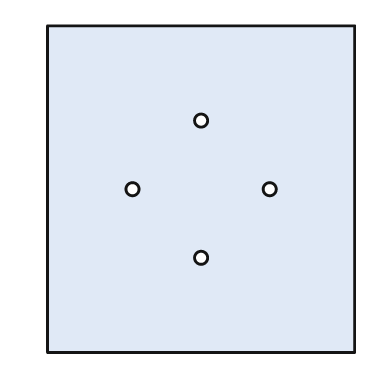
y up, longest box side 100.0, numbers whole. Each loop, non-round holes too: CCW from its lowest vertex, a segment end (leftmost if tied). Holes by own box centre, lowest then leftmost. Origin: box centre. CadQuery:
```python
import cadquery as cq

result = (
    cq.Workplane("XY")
    .moveTo(-47.0, -50.0)
    .lineTo(47.0, -50.0)
    .lineTo(47.0, 50.0)
    .lineTo(-47.0, 50.0)
    .close()
    .moveTo(0.0, -21.0)
    .circle(2.0)
    .moveTo(-21.0, 0.0)
    .circle(2.0)
    .moveTo(21.0, 0.0)
    .circle(2.0)
    .moveTo(0.0, 21.0)
    .circle(2.0)
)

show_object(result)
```